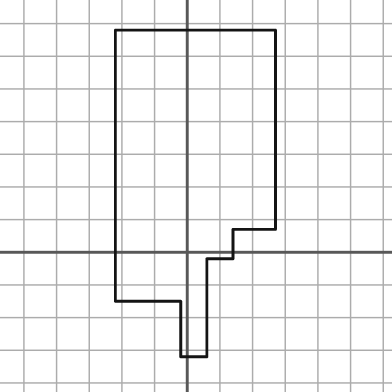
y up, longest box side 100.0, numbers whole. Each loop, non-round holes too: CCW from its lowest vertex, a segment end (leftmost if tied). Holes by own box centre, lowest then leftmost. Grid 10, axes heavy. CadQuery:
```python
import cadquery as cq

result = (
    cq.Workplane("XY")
    .moveTo(-2.0, -32.0)
    .lineTo(6.0, -32.0)
    .lineTo(6.0, -2.0)
    .lineTo(14.0, -2.0)
    .lineTo(14.0, 7.0)
    .lineTo(27.0, 7.0)
    .lineTo(27.0, 68.0)
    .lineTo(-22.0, 68.0)
    .lineTo(-22.0, -15.0)
    .lineTo(-2.0, -15.0)
    .close()
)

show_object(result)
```